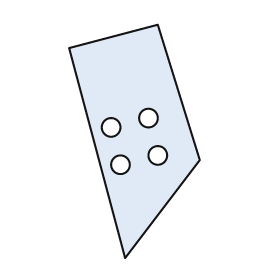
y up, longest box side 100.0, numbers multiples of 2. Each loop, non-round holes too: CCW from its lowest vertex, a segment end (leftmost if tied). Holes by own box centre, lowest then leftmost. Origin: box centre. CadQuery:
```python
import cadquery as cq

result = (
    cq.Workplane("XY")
    .moveTo(-4.0, -50.0)
    .lineTo(28.0, -8.0)
    .lineTo(10.0, 50.0)
    .lineTo(-28.0, 40.0)
    .close()
    .moveTo(-6.0, -10.0)
    .circle(4.0)
    .moveTo(10.0, -6.0)
    .circle(4.0)
    .moveTo(-10.0, 6.0)
    .circle(4.0)
    .moveTo(6.0, 10.0)
    .circle(4.0)
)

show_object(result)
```